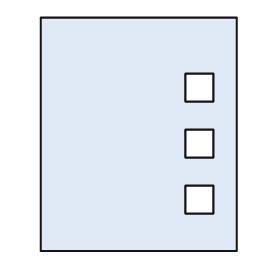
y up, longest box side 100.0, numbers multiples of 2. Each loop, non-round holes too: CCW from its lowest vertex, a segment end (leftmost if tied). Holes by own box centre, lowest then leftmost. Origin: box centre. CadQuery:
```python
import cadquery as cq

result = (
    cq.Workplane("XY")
    .moveTo(-42.0, -50.0)
    .lineTo(42.0, -50.0)
    .lineTo(42.0, 50.0)
    .lineTo(-42.0, 50.0)
    .close()
    .moveTo(20.0, -34.0)
    .lineTo(32.0, -34.0)
    .lineTo(32.0, -22.0)
    .lineTo(20.0, -22.0)
    .close()
    .moveTo(20.0, -10.0)
    .lineTo(32.0, -10.0)
    .lineTo(32.0, 2.0)
    .lineTo(20.0, 2.0)
    .close()
    .moveTo(20.0, 14.0)
    .lineTo(32.0, 14.0)
    .lineTo(32.0, 26.0)
    .lineTo(20.0, 26.0)
    .close()
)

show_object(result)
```